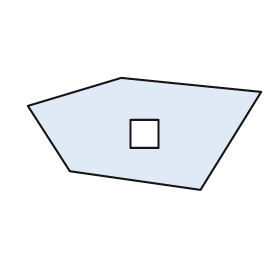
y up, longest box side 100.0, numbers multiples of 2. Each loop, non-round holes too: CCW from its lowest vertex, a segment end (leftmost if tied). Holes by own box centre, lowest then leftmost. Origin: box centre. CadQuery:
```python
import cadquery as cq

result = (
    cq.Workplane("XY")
    .moveTo(24.0, -24.0)
    .lineTo(50.0, 18.0)
    .lineTo(-10.0, 24.0)
    .lineTo(-50.0, 12.0)
    .lineTo(-32.0, -16.0)
    .close()
    .moveTo(-6.0, -6.0)
    .lineTo(6.0, -6.0)
    .lineTo(6.0, 6.0)
    .lineTo(-6.0, 6.0)
    .close()
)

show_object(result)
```